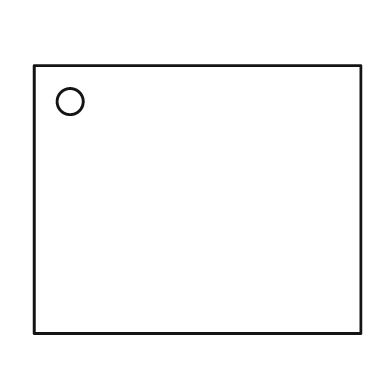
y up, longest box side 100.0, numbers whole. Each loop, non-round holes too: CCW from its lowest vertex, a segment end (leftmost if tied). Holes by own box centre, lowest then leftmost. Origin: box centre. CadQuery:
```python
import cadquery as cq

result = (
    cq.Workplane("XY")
    .moveTo(-50.0, -41.0)
    .lineTo(50.0, -41.0)
    .lineTo(50.0, 41.0)
    .lineTo(-50.0, 41.0)
    .close()
    .moveTo(-39.0, 30.0)
    .circle(4.0)
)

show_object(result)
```